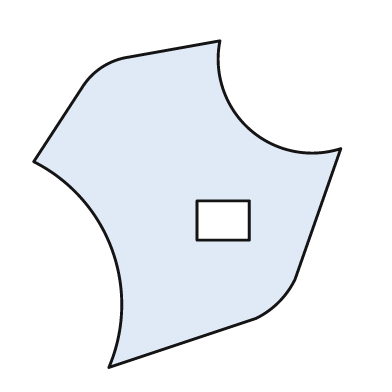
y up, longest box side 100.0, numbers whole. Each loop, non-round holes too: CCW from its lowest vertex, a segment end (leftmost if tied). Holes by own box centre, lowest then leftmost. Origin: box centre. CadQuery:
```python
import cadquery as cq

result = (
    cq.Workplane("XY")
    .moveTo(-24.0, -50.0)
    .lineTo(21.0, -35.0)
    .threePointArc((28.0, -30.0), (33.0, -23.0))
    .lineTo(47.0, 17.0)
    .threePointArc((19.0, 23.0), (10.0, 50.0))
    .lineTo(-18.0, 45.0)
    .threePointArc((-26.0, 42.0), (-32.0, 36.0))
    .lineTo(-47.0, 13.0)
    .threePointArc((-23.0, -14.0), (-24.0, -50.0))
    .close()
    .moveTo(3.0, -11.0)
    .lineTo(19.0, -11.0)
    .lineTo(19.0, 1.0)
    .lineTo(3.0, 1.0)
    .close()
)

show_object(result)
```